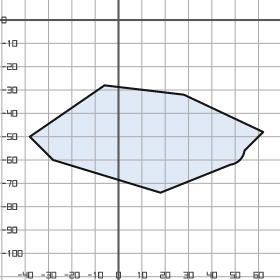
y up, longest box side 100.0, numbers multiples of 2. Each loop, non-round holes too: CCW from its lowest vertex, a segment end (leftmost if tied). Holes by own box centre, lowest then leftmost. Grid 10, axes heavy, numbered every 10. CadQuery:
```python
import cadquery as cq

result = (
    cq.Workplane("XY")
    .moveTo(18.0, -74.0)
    .lineTo(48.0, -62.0)
    .threePointArc((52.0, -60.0), (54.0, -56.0))
    .lineTo(62.0, -48.0)
    .lineTo(28.0, -32.0)
    .lineTo(-6.0, -28.0)
    .lineTo(-38.0, -50.0)
    .lineTo(-28.0, -60.0)
    .close()
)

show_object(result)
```